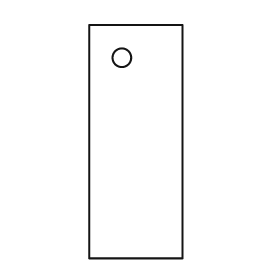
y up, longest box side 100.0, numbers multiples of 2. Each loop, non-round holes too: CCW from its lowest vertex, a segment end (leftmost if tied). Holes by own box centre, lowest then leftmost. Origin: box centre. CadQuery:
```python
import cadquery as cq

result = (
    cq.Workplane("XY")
    .moveTo(-20.0, -50.0)
    .lineTo(20.0, -50.0)
    .lineTo(20.0, 50.0)
    .lineTo(-20.0, 50.0)
    .close()
    .moveTo(-6.0, 36.0)
    .circle(4.0)
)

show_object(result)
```